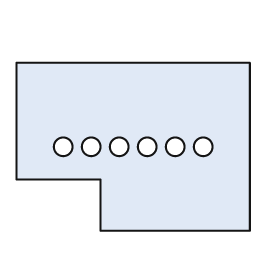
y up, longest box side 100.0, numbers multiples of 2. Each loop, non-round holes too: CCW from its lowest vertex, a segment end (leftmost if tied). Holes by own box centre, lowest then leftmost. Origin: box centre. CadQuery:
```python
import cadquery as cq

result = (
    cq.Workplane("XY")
    .moveTo(-14.0, -36.0)
    .lineTo(50.0, -36.0)
    .lineTo(50.0, 36.0)
    .lineTo(-50.0, 36.0)
    .lineTo(-50.0, -14.0)
    .lineTo(-14.0, -14.0)
    .close()
    .moveTo(-30.0, 0.0)
    .circle(4.0)
    .moveTo(-18.0, 0.0)
    .circle(4.0)
    .moveTo(-6.0, 0.0)
    .circle(4.0)
    .moveTo(6.0, 0.0)
    .circle(4.0)
    .moveTo(18.0, 0.0)
    .circle(4.0)
    .moveTo(30.0, 0.0)
    .circle(4.0)
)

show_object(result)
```